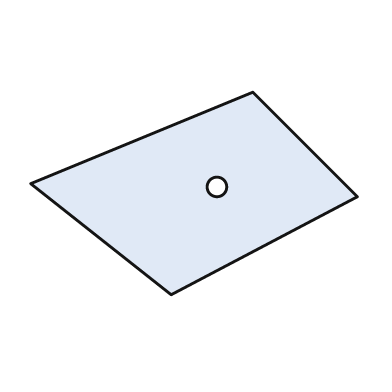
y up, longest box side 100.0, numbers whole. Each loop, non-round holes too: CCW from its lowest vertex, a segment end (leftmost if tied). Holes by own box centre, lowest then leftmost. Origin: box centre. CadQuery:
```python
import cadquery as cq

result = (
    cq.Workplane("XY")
    .moveTo(-7.0, -31.0)
    .lineTo(50.0, -1.0)
    .lineTo(18.0, 31.0)
    .lineTo(-50.0, 3.0)
    .close()
    .moveTo(7.0, 2.0)
    .circle(3.0)
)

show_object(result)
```